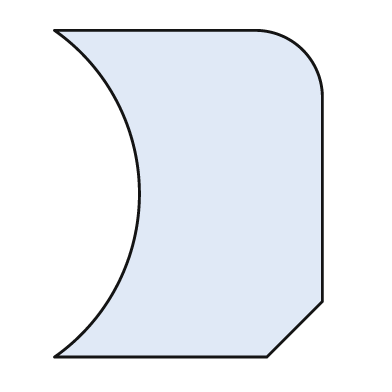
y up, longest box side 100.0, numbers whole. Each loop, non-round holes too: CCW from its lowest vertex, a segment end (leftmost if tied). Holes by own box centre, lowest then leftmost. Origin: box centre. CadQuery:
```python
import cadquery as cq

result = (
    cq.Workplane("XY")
    .moveTo(-41.0, -50.0)
    .lineTo(24.0, -50.0)
    .lineTo(41.0, -33.0)
    .lineTo(41.0, 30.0)
    .threePointArc((35.0, 44.0), (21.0, 50.0))
    .lineTo(-41.0, 50.0)
    .threePointArc((-15.0, 0.0), (-41.0, -50.0))
    .close()
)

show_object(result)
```